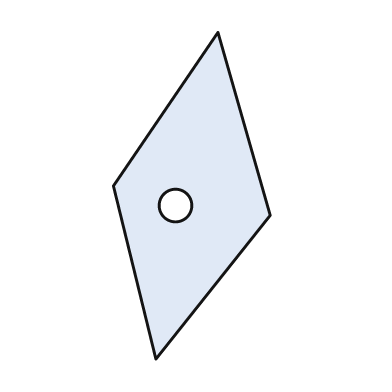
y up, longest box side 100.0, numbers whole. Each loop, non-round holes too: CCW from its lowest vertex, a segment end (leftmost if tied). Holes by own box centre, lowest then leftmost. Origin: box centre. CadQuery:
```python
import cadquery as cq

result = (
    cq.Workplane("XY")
    .moveTo(-11.0, -50.0)
    .lineTo(24.0, -6.0)
    .lineTo(8.0, 50.0)
    .lineTo(-24.0, 3.0)
    .close()
    .moveTo(-5.0, -3.0)
    .circle(5.0)
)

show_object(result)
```